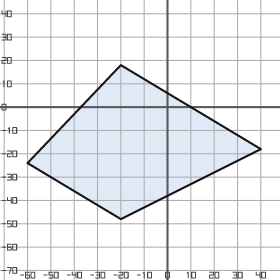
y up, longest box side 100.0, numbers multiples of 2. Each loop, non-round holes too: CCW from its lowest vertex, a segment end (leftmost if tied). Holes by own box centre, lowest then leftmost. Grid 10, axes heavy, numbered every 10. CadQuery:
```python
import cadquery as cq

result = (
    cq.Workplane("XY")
    .moveTo(-20.0, -48.0)
    .lineTo(40.0, -18.0)
    .lineTo(-20.0, 18.0)
    .lineTo(-60.0, -24.0)
    .close()
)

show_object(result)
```